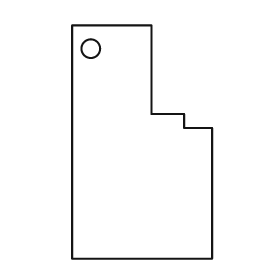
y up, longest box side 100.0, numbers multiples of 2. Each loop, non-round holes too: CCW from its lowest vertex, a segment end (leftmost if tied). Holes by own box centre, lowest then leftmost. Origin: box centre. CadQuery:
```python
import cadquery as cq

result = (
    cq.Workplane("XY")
    .moveTo(-30.0, -50.0)
    .lineTo(30.0, -50.0)
    .lineTo(30.0, 6.0)
    .lineTo(18.0, 6.0)
    .lineTo(18.0, 12.0)
    .lineTo(4.0, 12.0)
    .lineTo(4.0, 50.0)
    .lineTo(-30.0, 50.0)
    .close()
    .moveTo(-22.0, 40.0)
    .circle(4.0)
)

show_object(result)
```